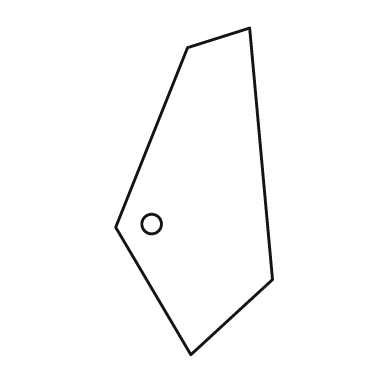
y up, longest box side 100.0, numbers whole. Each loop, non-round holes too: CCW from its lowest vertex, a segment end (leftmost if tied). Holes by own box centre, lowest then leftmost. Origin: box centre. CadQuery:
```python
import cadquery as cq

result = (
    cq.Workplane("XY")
    .moveTo(-1.0, -50.0)
    .lineTo(24.0, -27.0)
    .lineTo(17.0, 50.0)
    .lineTo(-2.0, 44.0)
    .lineTo(-24.0, -11.0)
    .close()
    .moveTo(-13.0, -10.0)
    .circle(3.0)
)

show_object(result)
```